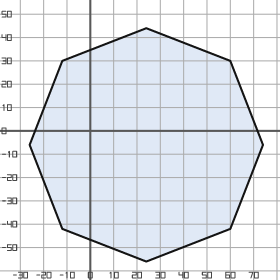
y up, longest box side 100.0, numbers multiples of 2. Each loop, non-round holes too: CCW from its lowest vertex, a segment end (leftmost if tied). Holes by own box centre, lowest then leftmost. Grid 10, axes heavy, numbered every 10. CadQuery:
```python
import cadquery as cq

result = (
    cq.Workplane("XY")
    .moveTo(24.0, -56.0)
    .lineTo(60.0, -42.0)
    .lineTo(74.0, -6.0)
    .lineTo(60.0, 30.0)
    .lineTo(24.0, 44.0)
    .lineTo(-12.0, 30.0)
    .lineTo(-26.0, -6.0)
    .lineTo(-12.0, -42.0)
    .close()
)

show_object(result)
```